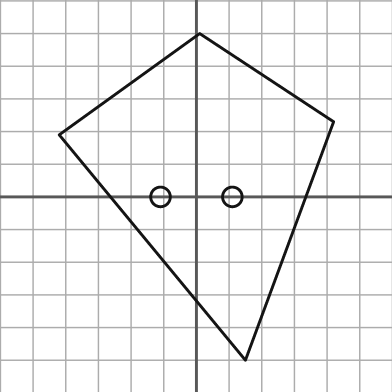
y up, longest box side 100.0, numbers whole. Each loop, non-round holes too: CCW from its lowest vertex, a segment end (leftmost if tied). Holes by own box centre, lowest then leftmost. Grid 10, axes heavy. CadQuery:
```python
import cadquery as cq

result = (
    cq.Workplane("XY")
    .moveTo(15.0, -50.0)
    .lineTo(42.0, 23.0)
    .lineTo(1.0, 50.0)
    .lineTo(-42.0, 19.0)
    .close()
    .moveTo(-11.0, 0.0)
    .circle(3.0)
    .moveTo(11.0, 0.0)
    .circle(3.0)
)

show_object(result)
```